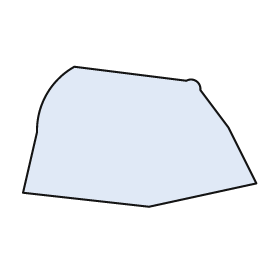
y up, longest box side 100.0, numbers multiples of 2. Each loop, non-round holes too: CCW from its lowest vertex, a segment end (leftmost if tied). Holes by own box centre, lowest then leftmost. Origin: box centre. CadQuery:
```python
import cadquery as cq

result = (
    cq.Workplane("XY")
    .moveTo(4.0, -30.0)
    .lineTo(50.0, -20.0)
    .lineTo(38.0, 4.0)
    .lineTo(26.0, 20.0)
    .threePointArc((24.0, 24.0), (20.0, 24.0))
    .lineTo(-28.0, 30.0)
    .threePointArc((-40.0, 18.0), (-44.0, 2.0))
    .lineTo(-50.0, -24.0)
    .close()
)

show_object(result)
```